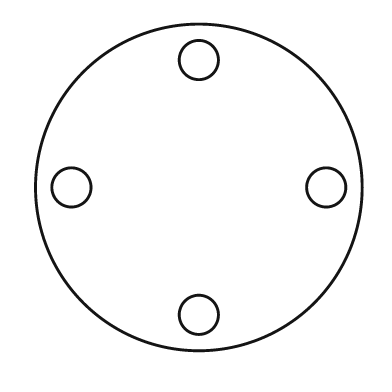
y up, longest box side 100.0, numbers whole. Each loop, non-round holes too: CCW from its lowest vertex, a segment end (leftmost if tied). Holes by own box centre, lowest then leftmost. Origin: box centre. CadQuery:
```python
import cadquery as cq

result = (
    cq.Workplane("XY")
    .moveTo(0.0, 0.0)
    .circle(50.0)
    .moveTo(0.0, -39.0)
    .circle(6.0)
    .moveTo(-39.0, 0.0)
    .circle(6.0)
    .moveTo(39.0, 0.0)
    .circle(6.0)
    .moveTo(0.0, 39.0)
    .circle(6.0)
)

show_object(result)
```